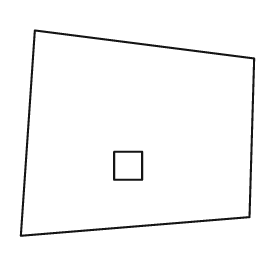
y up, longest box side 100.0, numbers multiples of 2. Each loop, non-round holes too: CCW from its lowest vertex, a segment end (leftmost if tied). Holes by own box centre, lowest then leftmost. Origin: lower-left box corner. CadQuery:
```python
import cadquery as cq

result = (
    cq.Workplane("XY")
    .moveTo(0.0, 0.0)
    .lineTo(98.0, 8.0)
    .lineTo(100.0, 76.0)
    .lineTo(6.0, 88.0)
    .close()
    .moveTo(40.0, 24.0)
    .lineTo(52.0, 24.0)
    .lineTo(52.0, 36.0)
    .lineTo(40.0, 36.0)
    .close()
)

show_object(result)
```